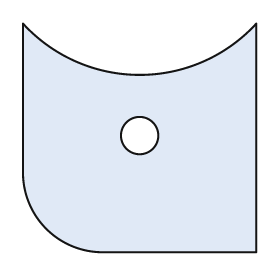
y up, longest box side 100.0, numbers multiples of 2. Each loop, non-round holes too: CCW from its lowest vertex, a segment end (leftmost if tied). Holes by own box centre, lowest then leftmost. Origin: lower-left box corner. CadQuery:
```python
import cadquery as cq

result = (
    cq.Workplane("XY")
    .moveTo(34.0, 0.0)
    .lineTo(100.0, 0.0)
    .lineTo(100.0, 98.0)
    .threePointArc((50.0, 76.0), (0.0, 98.0))
    .lineTo(0.0, 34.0)
    .threePointArc((10.0, 10.0), (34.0, 0.0))
    .close()
    .moveTo(50.0, 50.0)
    .circle(8.0)
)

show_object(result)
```